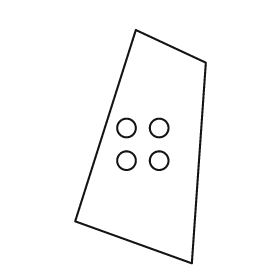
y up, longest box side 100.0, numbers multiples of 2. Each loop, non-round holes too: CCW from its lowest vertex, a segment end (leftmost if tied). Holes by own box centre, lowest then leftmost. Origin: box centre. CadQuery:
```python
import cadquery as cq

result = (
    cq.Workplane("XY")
    .moveTo(22.0, -50.0)
    .lineTo(28.0, 36.0)
    .lineTo(-2.0, 50.0)
    .lineTo(-28.0, -32.0)
    .close()
    .moveTo(-6.0, -6.0)
    .circle(4.0)
    .moveTo(8.0, -6.0)
    .circle(4.0)
    .moveTo(-6.0, 8.0)
    .circle(4.0)
    .moveTo(8.0, 8.0)
    .circle(4.0)
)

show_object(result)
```